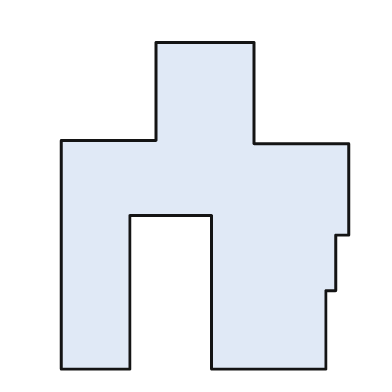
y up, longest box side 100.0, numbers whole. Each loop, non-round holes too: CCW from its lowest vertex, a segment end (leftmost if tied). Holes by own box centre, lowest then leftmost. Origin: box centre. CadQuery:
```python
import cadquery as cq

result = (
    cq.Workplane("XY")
    .moveTo(-44.0, -50.0)
    .lineTo(-23.0, -50.0)
    .lineTo(-23.0, -3.0)
    .lineTo(2.0, -3.0)
    .lineTo(2.0, -50.0)
    .lineTo(37.0, -50.0)
    .lineTo(37.0, -26.0)
    .lineTo(40.0, -26.0)
    .lineTo(40.0, -9.0)
    .lineTo(44.0, -9.0)
    .lineTo(44.0, 19.0)
    .lineTo(15.0, 19.0)
    .lineTo(15.0, 50.0)
    .lineTo(-15.0, 50.0)
    .lineTo(-15.0, 20.0)
    .lineTo(-44.0, 20.0)
    .close()
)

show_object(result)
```